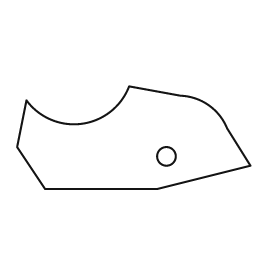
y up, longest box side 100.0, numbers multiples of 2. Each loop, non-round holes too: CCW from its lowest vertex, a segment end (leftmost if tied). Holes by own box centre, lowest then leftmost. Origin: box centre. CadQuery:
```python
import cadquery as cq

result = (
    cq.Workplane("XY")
    .moveTo(-38.0, -22.0)
    .lineTo(10.0, -22.0)
    .lineTo(50.0, -12.0)
    .lineTo(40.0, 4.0)
    .threePointArc((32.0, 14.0), (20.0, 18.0))
    .lineTo(-2.0, 22.0)
    .threePointArc((-22.0, 6.0), (-46.0, 16.0))
    .lineTo(-50.0, -4.0)
    .close()
    .moveTo(14.0, -8.0)
    .circle(4.0)
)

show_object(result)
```